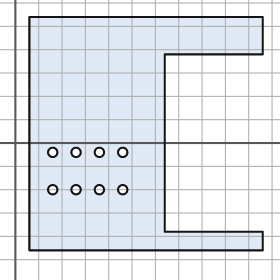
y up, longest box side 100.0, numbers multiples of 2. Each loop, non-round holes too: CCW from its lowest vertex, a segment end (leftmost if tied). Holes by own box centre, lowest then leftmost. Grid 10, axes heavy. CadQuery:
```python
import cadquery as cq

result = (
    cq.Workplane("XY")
    .moveTo(6.0, -46.0)
    .lineTo(106.0, -46.0)
    .lineTo(106.0, -38.0)
    .lineTo(64.0, -38.0)
    .lineTo(64.0, 38.0)
    .lineTo(106.0, 38.0)
    .lineTo(106.0, 54.0)
    .lineTo(6.0, 54.0)
    .close()
    .moveTo(16.0, -20.0)
    .circle(2.0)
    .moveTo(26.0, -20.0)
    .circle(2.0)
    .moveTo(36.0, -20.0)
    .circle(2.0)
    .moveTo(46.0, -20.0)
    .circle(2.0)
    .moveTo(16.0, -4.0)
    .circle(2.0)
    .moveTo(26.0, -4.0)
    .circle(2.0)
    .moveTo(36.0, -4.0)
    .circle(2.0)
    .moveTo(46.0, -4.0)
    .circle(2.0)
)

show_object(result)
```